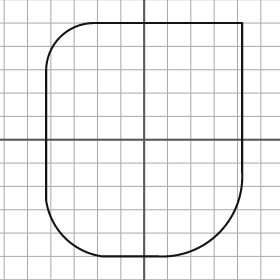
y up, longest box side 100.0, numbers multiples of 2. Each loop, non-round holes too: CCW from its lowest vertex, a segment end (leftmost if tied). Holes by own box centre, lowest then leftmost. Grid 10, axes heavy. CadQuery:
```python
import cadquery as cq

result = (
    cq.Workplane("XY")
    .moveTo(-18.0, -50.0)
    .lineTo(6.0, -50.0)
    .threePointArc((32.0, -40.0), (42.0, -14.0))
    .lineTo(42.0, 50.0)
    .lineTo(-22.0, 50.0)
    .threePointArc((-36.0, 44.0), (-42.0, 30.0))
    .lineTo(-42.0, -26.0)
    .threePointArc((-34.0, -42.0), (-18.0, -50.0))
    .close()
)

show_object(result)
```